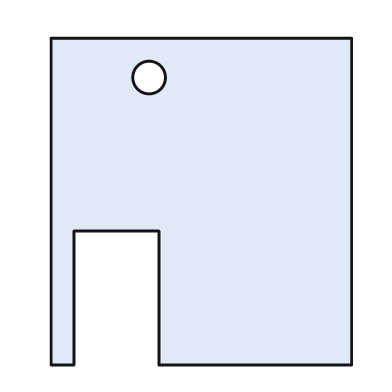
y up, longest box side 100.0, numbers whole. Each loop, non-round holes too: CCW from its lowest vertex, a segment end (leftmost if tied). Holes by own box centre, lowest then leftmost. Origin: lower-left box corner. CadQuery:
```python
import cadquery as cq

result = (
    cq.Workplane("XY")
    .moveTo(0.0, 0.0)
    .lineTo(7.0, 0.0)
    .lineTo(7.0, 41.0)
    .lineTo(33.0, 41.0)
    .lineTo(33.0, 0.0)
    .lineTo(92.0, 0.0)
    .lineTo(92.0, 100.0)
    .lineTo(0.0, 100.0)
    .close()
    .moveTo(30.0, 88.0)
    .circle(5.0)
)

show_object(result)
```